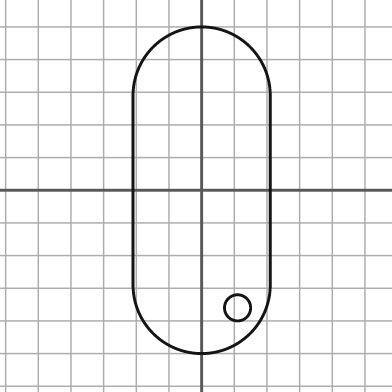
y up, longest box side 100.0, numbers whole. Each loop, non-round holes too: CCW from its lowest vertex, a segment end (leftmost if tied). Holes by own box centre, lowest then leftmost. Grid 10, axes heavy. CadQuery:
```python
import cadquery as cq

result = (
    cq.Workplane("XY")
    .moveTo(-21.0, -29.0)
    .threePointArc((0.0, -50.0), (21.0, -29.0))
    .lineTo(21.0, 29.0)
    .threePointArc((0.0, 50.0), (-21.0, 29.0))
    .close()
    .moveTo(11.0, -36.0)
    .circle(4.0)
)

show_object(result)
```